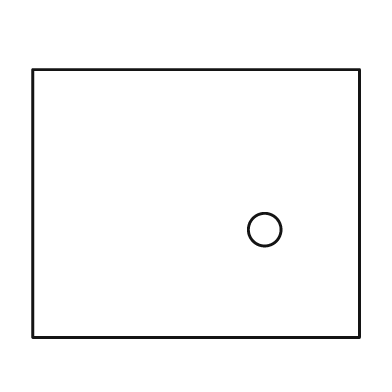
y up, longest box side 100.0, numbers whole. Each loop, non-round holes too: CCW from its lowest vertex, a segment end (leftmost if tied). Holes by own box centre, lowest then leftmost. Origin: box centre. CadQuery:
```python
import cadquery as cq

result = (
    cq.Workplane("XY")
    .moveTo(-50.0, -41.0)
    .lineTo(50.0, -41.0)
    .lineTo(50.0, 41.0)
    .lineTo(-50.0, 41.0)
    .close()
    .moveTo(21.0, -8.0)
    .circle(5.0)
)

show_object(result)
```